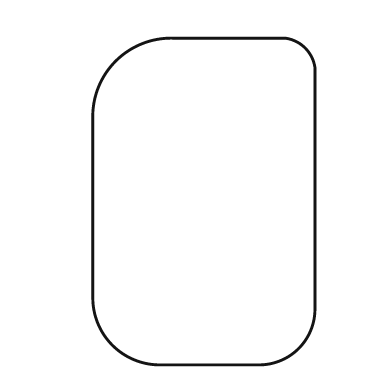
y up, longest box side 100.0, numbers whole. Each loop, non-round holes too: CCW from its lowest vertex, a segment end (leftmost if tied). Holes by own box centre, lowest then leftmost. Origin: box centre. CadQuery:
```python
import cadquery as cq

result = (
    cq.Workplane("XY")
    .moveTo(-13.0, -50.0)
    .lineTo(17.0, -50.0)
    .threePointArc((29.0, -45.0), (34.0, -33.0))
    .lineTo(34.0, 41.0)
    .threePointArc((31.0, 47.0), (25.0, 50.0))
    .lineTo(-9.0, 50.0)
    .threePointArc((-27.0, 43.0), (-34.0, 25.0))
    .lineTo(-34.0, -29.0)
    .threePointArc((-28.0, -44.0), (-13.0, -50.0))
    .close()
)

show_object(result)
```